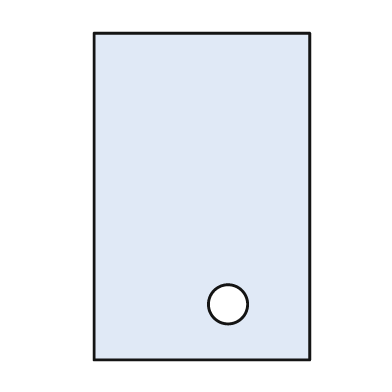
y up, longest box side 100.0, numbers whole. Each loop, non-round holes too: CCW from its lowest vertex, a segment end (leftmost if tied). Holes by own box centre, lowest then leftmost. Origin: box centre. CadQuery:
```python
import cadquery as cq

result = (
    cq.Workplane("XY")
    .moveTo(-33.0, -50.0)
    .lineTo(33.0, -50.0)
    .lineTo(33.0, 50.0)
    .lineTo(-33.0, 50.0)
    .close()
    .moveTo(8.0, -33.0)
    .circle(6.0)
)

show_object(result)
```